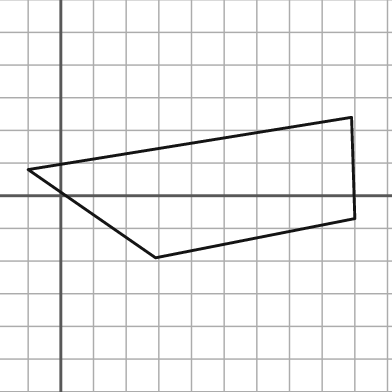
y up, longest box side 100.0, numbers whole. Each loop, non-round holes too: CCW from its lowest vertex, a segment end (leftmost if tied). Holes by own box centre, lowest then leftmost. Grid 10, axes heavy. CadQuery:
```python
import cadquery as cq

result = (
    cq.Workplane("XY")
    .moveTo(29.0, -19.0)
    .lineTo(90.0, -7.0)
    .lineTo(89.0, 24.0)
    .lineTo(-10.0, 8.0)
    .close()
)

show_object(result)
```